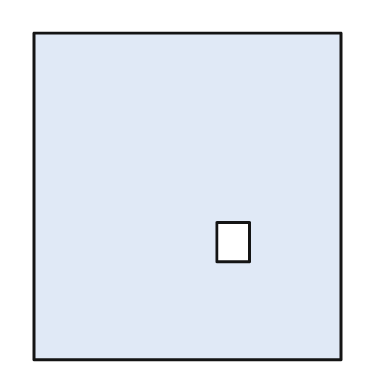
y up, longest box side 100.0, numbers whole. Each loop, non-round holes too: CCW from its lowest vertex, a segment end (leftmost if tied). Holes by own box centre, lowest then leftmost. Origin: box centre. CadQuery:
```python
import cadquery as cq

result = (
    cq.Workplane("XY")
    .moveTo(-47.0, -50.0)
    .lineTo(47.0, -50.0)
    .lineTo(47.0, 50.0)
    .lineTo(-47.0, 50.0)
    .close()
    .moveTo(9.0, -20.0)
    .lineTo(19.0, -20.0)
    .lineTo(19.0, -8.0)
    .lineTo(9.0, -8.0)
    .close()
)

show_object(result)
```